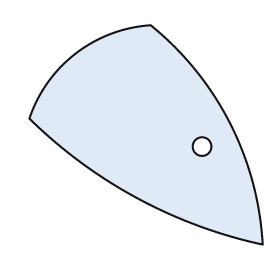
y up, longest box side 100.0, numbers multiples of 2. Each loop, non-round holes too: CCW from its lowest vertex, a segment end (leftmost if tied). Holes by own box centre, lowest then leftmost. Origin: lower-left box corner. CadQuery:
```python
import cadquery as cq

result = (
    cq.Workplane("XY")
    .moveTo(100.0, 0.0)
    .threePointArc((86.0, 52.0), (52.0, 94.0))
    .threePointArc((20.0, 82.0), (0.0, 54.0))
    .threePointArc((46.0, 20.0), (100.0, 0.0))
    .close()
    .moveTo(74.0, 42.0)
    .circle(4.0)
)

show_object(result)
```